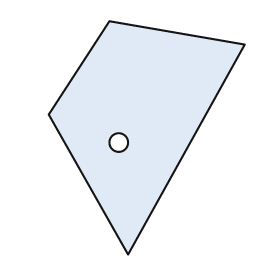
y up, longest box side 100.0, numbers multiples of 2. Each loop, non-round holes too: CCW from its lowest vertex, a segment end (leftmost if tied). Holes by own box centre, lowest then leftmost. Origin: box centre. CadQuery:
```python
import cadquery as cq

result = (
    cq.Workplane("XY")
    .moveTo(-8.0, -50.0)
    .lineTo(42.0, 40.0)
    .lineTo(-16.0, 50.0)
    .lineTo(-42.0, 10.0)
    .close()
    .moveTo(-12.0, -2.0)
    .circle(4.0)
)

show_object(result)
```